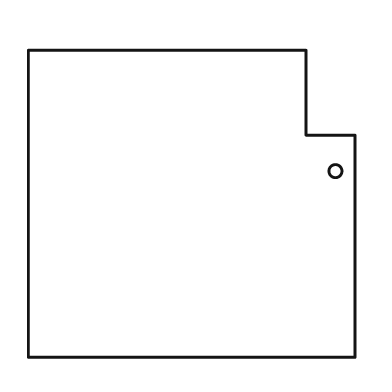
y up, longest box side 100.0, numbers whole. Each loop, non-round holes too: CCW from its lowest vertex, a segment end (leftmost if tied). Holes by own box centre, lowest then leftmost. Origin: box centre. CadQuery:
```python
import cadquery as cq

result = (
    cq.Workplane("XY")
    .moveTo(-50.0, -47.0)
    .lineTo(50.0, -47.0)
    .lineTo(50.0, 21.0)
    .lineTo(35.0, 21.0)
    .lineTo(35.0, 47.0)
    .lineTo(-50.0, 47.0)
    .close()
    .moveTo(44.0, 10.0)
    .circle(2.0)
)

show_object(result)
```